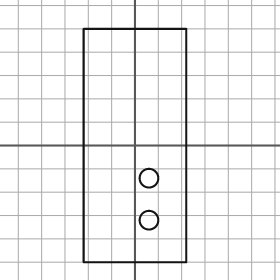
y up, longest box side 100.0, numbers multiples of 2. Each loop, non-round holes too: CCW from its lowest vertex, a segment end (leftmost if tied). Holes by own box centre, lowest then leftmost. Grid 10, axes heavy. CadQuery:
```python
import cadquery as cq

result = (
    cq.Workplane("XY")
    .moveTo(-22.0, -50.0)
    .lineTo(22.0, -50.0)
    .lineTo(22.0, 50.0)
    .lineTo(-22.0, 50.0)
    .close()
    .moveTo(6.0, -32.0)
    .circle(4.0)
    .moveTo(6.0, -14.0)
    .circle(4.0)
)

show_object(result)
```